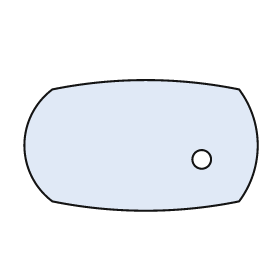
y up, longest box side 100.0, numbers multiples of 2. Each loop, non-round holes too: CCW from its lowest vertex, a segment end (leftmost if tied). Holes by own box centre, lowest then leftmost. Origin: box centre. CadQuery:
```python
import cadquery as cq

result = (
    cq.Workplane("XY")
    .moveTo(-38.0, -24.0)
    .threePointArc((2.0, -28.0), (42.0, -24.0))
    .threePointArc((50.0, 0.0), (42.0, 24.0))
    .threePointArc((2.0, 28.0), (-38.0, 24.0))
    .threePointArc((-50.0, 0.0), (-38.0, -24.0))
    .close()
    .moveTo(26.0, -6.0)
    .circle(4.0)
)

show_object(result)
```